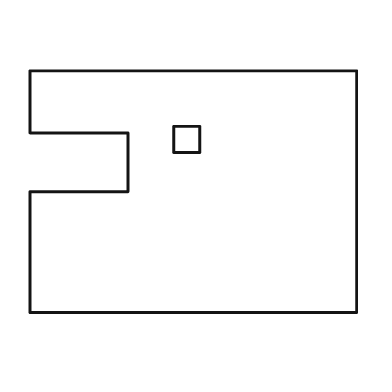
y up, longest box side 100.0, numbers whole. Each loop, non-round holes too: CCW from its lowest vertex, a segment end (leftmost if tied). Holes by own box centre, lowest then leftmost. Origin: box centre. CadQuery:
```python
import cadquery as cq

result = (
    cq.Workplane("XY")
    .moveTo(-50.0, -37.0)
    .lineTo(50.0, -37.0)
    .lineTo(50.0, 37.0)
    .lineTo(-50.0, 37.0)
    .lineTo(-50.0, 18.0)
    .lineTo(-20.0, 18.0)
    .lineTo(-20.0, 0.0)
    .lineTo(-50.0, 0.0)
    .close()
    .moveTo(-6.0, 12.0)
    .lineTo(2.0, 12.0)
    .lineTo(2.0, 20.0)
    .lineTo(-6.0, 20.0)
    .close()
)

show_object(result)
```